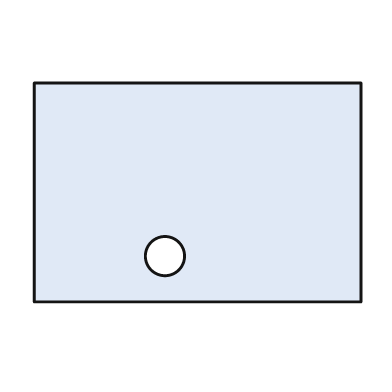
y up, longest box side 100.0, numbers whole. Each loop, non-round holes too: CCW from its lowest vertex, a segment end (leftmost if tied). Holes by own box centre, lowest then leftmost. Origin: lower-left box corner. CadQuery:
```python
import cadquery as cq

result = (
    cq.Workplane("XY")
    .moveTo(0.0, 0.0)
    .lineTo(100.0, 0.0)
    .lineTo(100.0, 67.0)
    .lineTo(0.0, 67.0)
    .close()
    .moveTo(40.0, 14.0)
    .circle(6.0)
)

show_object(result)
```